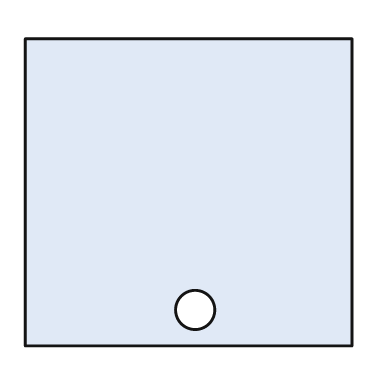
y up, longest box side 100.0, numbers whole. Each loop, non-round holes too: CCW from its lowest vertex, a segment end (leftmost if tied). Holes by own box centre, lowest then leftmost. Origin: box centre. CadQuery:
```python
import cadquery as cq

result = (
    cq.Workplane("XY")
    .moveTo(-50.0, -47.0)
    .lineTo(50.0, -47.0)
    .lineTo(50.0, 47.0)
    .lineTo(-50.0, 47.0)
    .close()
    .moveTo(2.0, -36.0)
    .circle(6.0)
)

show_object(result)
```